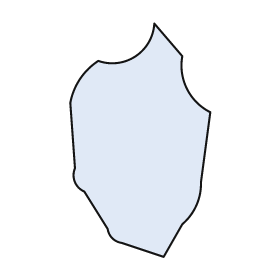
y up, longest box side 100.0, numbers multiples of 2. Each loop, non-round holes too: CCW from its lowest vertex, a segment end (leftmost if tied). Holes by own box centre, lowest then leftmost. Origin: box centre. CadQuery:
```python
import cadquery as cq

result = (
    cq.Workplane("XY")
    .moveTo(10.0, -50.0)
    .lineTo(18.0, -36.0)
    .threePointArc((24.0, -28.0), (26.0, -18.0))
    .lineTo(30.0, 12.0)
    .threePointArc((20.0, 22.0), (18.0, 36.0))
    .lineTo(6.0, 50.0)
    .threePointArc((-2.0, 36.0), (-18.0, 34.0))
    .threePointArc((-26.0, 26.0), (-30.0, 16.0))
    .lineTo(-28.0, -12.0)
    .threePointArc((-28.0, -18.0), (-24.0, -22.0))
    .lineTo(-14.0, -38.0)
    .threePointArc((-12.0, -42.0), (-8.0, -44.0))
    .close()
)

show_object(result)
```